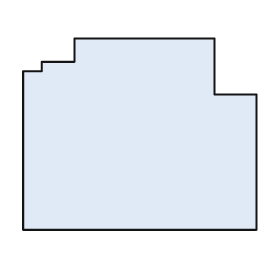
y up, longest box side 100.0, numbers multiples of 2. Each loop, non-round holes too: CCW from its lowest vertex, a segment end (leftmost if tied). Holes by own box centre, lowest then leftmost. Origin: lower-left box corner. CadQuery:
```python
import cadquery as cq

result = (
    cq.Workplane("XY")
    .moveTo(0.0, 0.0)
    .lineTo(100.0, 0.0)
    .lineTo(100.0, 58.0)
    .lineTo(82.0, 58.0)
    .lineTo(82.0, 82.0)
    .lineTo(22.0, 82.0)
    .lineTo(22.0, 72.0)
    .lineTo(8.0, 72.0)
    .lineTo(8.0, 68.0)
    .lineTo(0.0, 68.0)
    .close()
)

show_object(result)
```